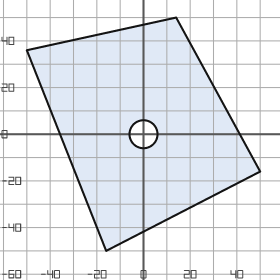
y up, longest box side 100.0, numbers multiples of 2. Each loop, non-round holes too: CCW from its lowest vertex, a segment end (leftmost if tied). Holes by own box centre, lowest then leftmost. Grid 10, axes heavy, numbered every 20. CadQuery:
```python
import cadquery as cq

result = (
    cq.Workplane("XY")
    .moveTo(-16.0, -50.0)
    .lineTo(50.0, -16.0)
    .lineTo(14.0, 50.0)
    .lineTo(-50.0, 36.0)
    .close()
    .moveTo(0.0, 0.0)
    .circle(6.0)
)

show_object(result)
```